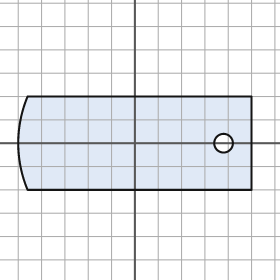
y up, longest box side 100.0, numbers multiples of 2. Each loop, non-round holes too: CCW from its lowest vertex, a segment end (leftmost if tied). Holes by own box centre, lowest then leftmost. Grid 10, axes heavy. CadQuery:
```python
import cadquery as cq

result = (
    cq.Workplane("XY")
    .moveTo(-46.0, -20.0)
    .lineTo(50.0, -20.0)
    .lineTo(50.0, 20.0)
    .lineTo(-46.0, 20.0)
    .threePointArc((-50.0, 0.0), (-46.0, -20.0))
    .close()
    .moveTo(38.0, 0.0)
    .circle(4.0)
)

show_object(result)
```